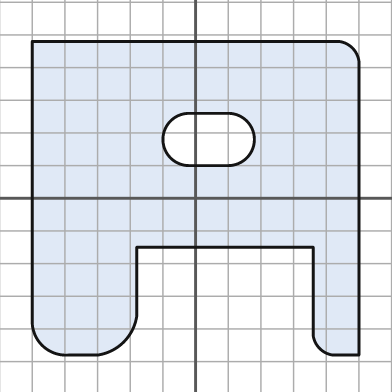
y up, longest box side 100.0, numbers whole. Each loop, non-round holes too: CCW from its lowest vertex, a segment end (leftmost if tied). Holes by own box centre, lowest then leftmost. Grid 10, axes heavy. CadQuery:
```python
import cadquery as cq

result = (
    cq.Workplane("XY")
    .moveTo(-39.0, -48.0)
    .lineTo(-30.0, -48.0)
    .threePointArc((-22.0, -44.0), (-18.0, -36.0))
    .lineTo(-18.0, -15.0)
    .lineTo(36.0, -15.0)
    .lineTo(36.0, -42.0)
    .threePointArc((38.0, -46.0), (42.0, -48.0))
    .lineTo(50.0, -48.0)
    .lineTo(50.0, 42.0)
    .threePointArc((48.0, 46.0), (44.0, 48.0))
    .lineTo(-50.0, 48.0)
    .lineTo(-50.0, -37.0)
    .threePointArc((-47.0, -45.0), (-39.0, -48.0))
    .close()
    .moveTo(-2.0, 10.0)
    .lineTo(10.0, 10.0)
    .threePointArc((18.0, 18.0), (10.0, 26.0))
    .lineTo(-2.0, 26.0)
    .threePointArc((-10.0, 18.0), (-2.0, 10.0))
    .close()
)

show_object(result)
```